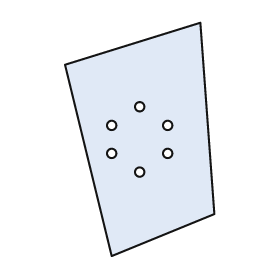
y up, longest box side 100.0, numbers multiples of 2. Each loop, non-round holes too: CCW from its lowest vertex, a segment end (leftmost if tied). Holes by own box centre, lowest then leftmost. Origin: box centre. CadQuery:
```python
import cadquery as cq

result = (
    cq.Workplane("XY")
    .moveTo(-12.0, -50.0)
    .lineTo(32.0, -32.0)
    .lineTo(26.0, 50.0)
    .lineTo(-32.0, 32.0)
    .close()
    .moveTo(0.0, -14.0)
    .circle(2.0)
    .moveTo(-12.0, -6.0)
    .circle(2.0)
    .moveTo(12.0, -6.0)
    .circle(2.0)
    .moveTo(-12.0, 6.0)
    .circle(2.0)
    .moveTo(12.0, 6.0)
    .circle(2.0)
    .moveTo(0.0, 14.0)
    .circle(2.0)
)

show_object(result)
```